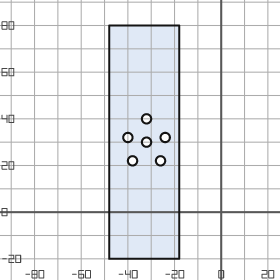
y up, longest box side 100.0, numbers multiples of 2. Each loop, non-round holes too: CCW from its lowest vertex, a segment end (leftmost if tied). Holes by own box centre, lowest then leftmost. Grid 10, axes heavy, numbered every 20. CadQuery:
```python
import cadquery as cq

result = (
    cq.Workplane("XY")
    .moveTo(-48.0, -20.0)
    .lineTo(-18.0, -20.0)
    .lineTo(-18.0, 80.0)
    .lineTo(-48.0, 80.0)
    .close()
    .moveTo(-38.0, 22.0)
    .circle(2.0)
    .moveTo(-26.0, 22.0)
    .circle(2.0)
    .moveTo(-32.0, 30.0)
    .circle(2.0)
    .moveTo(-40.0, 32.0)
    .circle(2.0)
    .moveTo(-24.0, 32.0)
    .circle(2.0)
    .moveTo(-32.0, 40.0)
    .circle(2.0)
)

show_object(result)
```